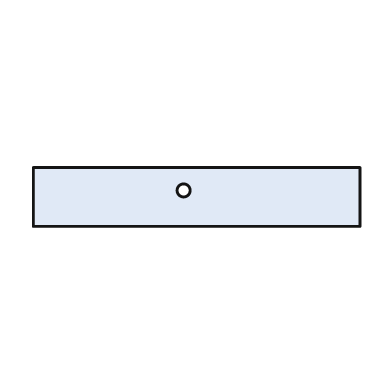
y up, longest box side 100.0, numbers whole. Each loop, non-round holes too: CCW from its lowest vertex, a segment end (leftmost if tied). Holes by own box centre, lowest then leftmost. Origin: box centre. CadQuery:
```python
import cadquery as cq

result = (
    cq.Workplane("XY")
    .moveTo(-50.0, -9.0)
    .lineTo(50.0, -9.0)
    .lineTo(50.0, 9.0)
    .lineTo(-50.0, 9.0)
    .close()
    .moveTo(-4.0, 2.0)
    .circle(2.0)
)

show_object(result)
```